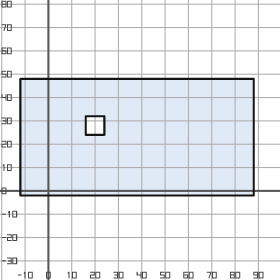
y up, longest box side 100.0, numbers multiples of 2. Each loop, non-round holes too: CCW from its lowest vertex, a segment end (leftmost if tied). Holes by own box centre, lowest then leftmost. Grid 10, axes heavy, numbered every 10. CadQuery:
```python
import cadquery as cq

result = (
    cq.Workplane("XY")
    .moveTo(-12.0, -2.0)
    .lineTo(88.0, -2.0)
    .lineTo(88.0, 48.0)
    .lineTo(-12.0, 48.0)
    .close()
    .moveTo(16.0, 24.0)
    .lineTo(24.0, 24.0)
    .lineTo(24.0, 32.0)
    .lineTo(16.0, 32.0)
    .close()
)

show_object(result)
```